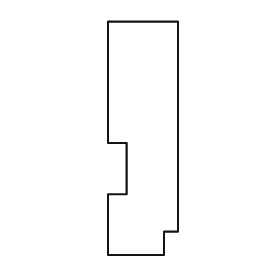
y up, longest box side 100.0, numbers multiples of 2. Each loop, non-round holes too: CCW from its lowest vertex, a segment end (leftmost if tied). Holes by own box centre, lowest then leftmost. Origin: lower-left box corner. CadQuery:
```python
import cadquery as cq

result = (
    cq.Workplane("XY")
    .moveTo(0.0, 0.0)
    .lineTo(24.0, 0.0)
    .lineTo(24.0, 10.0)
    .lineTo(30.0, 10.0)
    .lineTo(30.0, 100.0)
    .lineTo(0.0, 100.0)
    .lineTo(0.0, 48.0)
    .lineTo(8.0, 48.0)
    .lineTo(8.0, 26.0)
    .lineTo(0.0, 26.0)
    .close()
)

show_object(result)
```